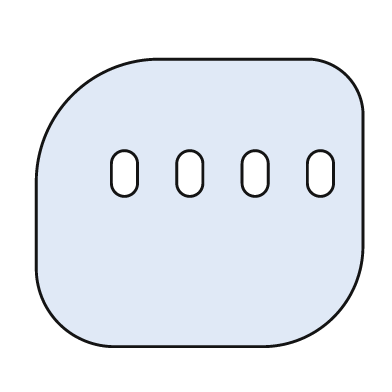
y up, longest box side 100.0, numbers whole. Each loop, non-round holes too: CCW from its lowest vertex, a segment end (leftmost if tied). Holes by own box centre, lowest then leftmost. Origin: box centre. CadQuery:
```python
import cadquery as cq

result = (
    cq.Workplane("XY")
    .moveTo(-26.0, -44.0)
    .lineTo(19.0, -44.0)
    .threePointArc((41.0, -35.0), (50.0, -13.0))
    .lineTo(50.0, 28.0)
    .threePointArc((45.0, 39.0), (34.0, 44.0))
    .lineTo(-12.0, 44.0)
    .threePointArc((-39.0, 33.0), (-50.0, 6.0))
    .lineTo(-50.0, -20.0)
    .threePointArc((-43.0, -37.0), (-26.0, -44.0))
    .close()
    .moveTo(-27.0, 6.0)
    .threePointArc((-23.0, 2.0), (-19.0, 6.0))
    .lineTo(-19.0, 12.0)
    .threePointArc((-23.0, 16.0), (-27.0, 12.0))
    .close()
    .moveTo(-7.0, 6.0)
    .threePointArc((-3.0, 2.0), (1.0, 6.0))
    .lineTo(1.0, 12.0)
    .threePointArc((-3.0, 16.0), (-7.0, 12.0))
    .close()
    .moveTo(13.0, 6.0)
    .threePointArc((17.0, 2.0), (21.0, 6.0))
    .lineTo(21.0, 12.0)
    .threePointArc((17.0, 16.0), (13.0, 12.0))
    .close()
    .moveTo(33.0, 6.0)
    .threePointArc((37.0, 2.0), (41.0, 6.0))
    .lineTo(41.0, 12.0)
    .threePointArc((37.0, 16.0), (33.0, 12.0))
    .close()
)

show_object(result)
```